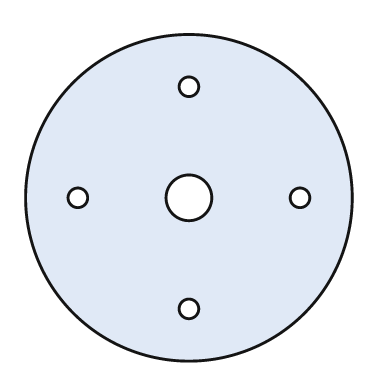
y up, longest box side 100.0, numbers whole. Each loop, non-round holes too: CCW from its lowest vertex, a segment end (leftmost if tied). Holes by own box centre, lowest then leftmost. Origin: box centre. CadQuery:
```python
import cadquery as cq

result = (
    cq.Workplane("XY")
    .moveTo(0.0, 0.0)
    .circle(50.0)
    .moveTo(0.0, -34.0)
    .circle(3.0)
    .moveTo(-34.0, 0.0)
    .circle(3.0)
    .moveTo(0.0, 0.0)
    .circle(7.0)
    .moveTo(34.0, 0.0)
    .circle(3.0)
    .moveTo(0.0, 34.0)
    .circle(3.0)
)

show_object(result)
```